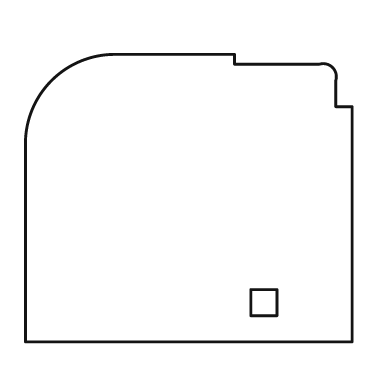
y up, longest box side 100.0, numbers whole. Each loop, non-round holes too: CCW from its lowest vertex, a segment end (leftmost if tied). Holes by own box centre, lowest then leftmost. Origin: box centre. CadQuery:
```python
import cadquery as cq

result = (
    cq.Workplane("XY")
    .moveTo(-50.0, -44.0)
    .lineTo(50.0, -44.0)
    .lineTo(50.0, 28.0)
    .lineTo(45.0, 28.0)
    .lineTo(45.0, 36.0)
    .threePointArc((44.0, 40.0), (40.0, 41.0))
    .lineTo(14.0, 41.0)
    .lineTo(14.0, 44.0)
    .lineTo(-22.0, 44.0)
    .threePointArc((-42.0, 36.0), (-50.0, 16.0))
    .close()
    .moveTo(19.0, -36.0)
    .lineTo(27.0, -36.0)
    .lineTo(27.0, -28.0)
    .lineTo(19.0, -28.0)
    .close()
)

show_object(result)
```